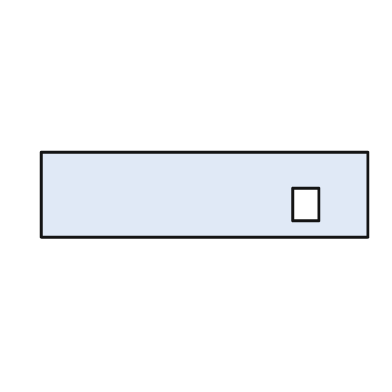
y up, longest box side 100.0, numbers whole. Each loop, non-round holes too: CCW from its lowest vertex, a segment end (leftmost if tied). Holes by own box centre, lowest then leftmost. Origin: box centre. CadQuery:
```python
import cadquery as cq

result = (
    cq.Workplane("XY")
    .moveTo(-50.0, -13.0)
    .lineTo(50.0, -13.0)
    .lineTo(50.0, 13.0)
    .lineTo(-50.0, 13.0)
    .close()
    .moveTo(27.0, -8.0)
    .lineTo(35.0, -8.0)
    .lineTo(35.0, 2.0)
    .lineTo(27.0, 2.0)
    .close()
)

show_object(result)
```